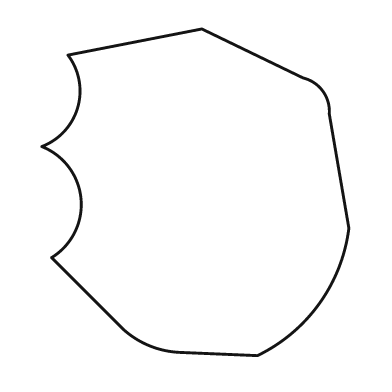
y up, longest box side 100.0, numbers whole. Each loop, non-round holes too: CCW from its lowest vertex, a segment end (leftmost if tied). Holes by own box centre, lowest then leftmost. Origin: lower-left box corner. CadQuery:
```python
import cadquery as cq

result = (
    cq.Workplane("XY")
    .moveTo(66.0, 0.0)
    .threePointArc((85.0, 16.0), (94.0, 39.0))
    .lineTo(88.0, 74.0)
    .threePointArc((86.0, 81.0), (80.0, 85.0))
    .lineTo(49.0, 100.0)
    .lineTo(8.0, 92.0)
    .threePointArc((11.0, 76.0), (0.0, 64.0))
    .threePointArc((12.0, 48.0), (3.0, 30.0))
    .lineTo(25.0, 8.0)
    .threePointArc((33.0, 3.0), (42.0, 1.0))
    .close()
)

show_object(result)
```